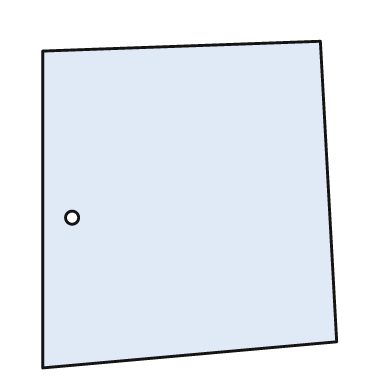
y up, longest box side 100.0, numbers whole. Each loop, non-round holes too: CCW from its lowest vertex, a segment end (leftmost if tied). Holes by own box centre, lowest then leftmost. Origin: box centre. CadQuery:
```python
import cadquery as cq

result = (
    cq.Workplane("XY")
    .moveTo(-45.0, -50.0)
    .lineTo(45.0, -42.0)
    .lineTo(40.0, 50.0)
    .lineTo(-45.0, 47.0)
    .close()
    .moveTo(-36.0, -4.0)
    .circle(2.0)
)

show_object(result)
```